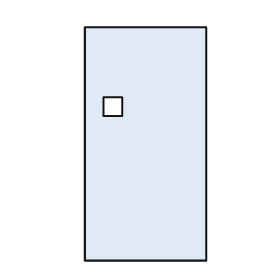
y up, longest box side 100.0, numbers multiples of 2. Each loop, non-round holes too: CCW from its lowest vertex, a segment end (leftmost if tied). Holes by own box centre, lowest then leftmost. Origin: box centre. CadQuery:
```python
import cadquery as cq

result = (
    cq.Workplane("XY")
    .moveTo(-26.0, -50.0)
    .lineTo(26.0, -50.0)
    .lineTo(26.0, 50.0)
    .lineTo(-26.0, 50.0)
    .close()
    .moveTo(-18.0, 12.0)
    .lineTo(-10.0, 12.0)
    .lineTo(-10.0, 20.0)
    .lineTo(-18.0, 20.0)
    .close()
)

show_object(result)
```